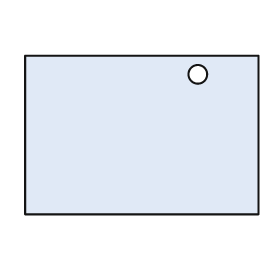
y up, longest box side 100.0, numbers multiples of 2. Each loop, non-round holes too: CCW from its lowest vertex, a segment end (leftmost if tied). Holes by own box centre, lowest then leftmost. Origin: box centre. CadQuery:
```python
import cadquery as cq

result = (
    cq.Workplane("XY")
    .moveTo(-50.0, -34.0)
    .lineTo(50.0, -34.0)
    .lineTo(50.0, 34.0)
    .lineTo(-50.0, 34.0)
    .close()
    .moveTo(24.0, 26.0)
    .circle(4.0)
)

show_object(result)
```